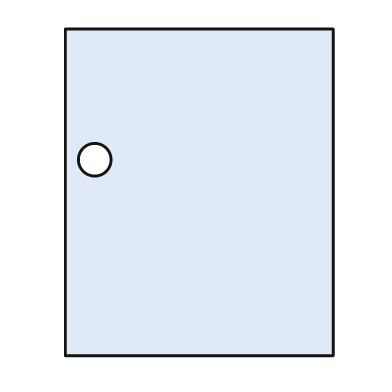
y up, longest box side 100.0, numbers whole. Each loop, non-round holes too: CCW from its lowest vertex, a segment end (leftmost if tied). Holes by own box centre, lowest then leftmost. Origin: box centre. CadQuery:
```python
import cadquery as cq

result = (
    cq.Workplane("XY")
    .moveTo(-41.0, -50.0)
    .lineTo(41.0, -50.0)
    .lineTo(41.0, 50.0)
    .lineTo(-41.0, 50.0)
    .close()
    .moveTo(-32.0, 10.0)
    .circle(5.0)
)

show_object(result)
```